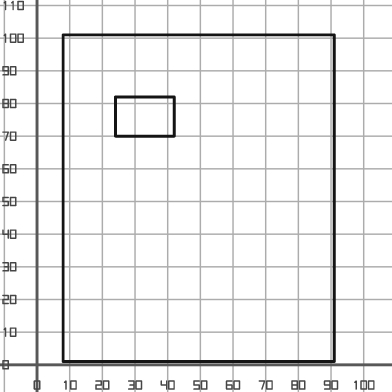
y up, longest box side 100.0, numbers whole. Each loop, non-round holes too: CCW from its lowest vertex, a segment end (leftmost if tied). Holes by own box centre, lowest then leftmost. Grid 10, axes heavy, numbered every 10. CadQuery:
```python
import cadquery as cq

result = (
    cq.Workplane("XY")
    .moveTo(8.0, 1.0)
    .lineTo(91.0, 1.0)
    .lineTo(91.0, 101.0)
    .lineTo(8.0, 101.0)
    .close()
    .moveTo(24.0, 70.0)
    .lineTo(42.0, 70.0)
    .lineTo(42.0, 82.0)
    .lineTo(24.0, 82.0)
    .close()
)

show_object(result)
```